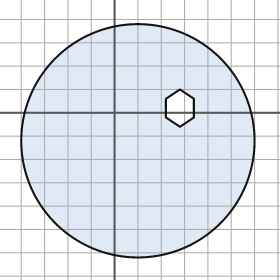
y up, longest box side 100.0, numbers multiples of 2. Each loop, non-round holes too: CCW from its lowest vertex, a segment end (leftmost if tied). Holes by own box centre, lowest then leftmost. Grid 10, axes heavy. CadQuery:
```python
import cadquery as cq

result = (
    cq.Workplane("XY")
    .moveTo(10.0, -12.0)
    .circle(50.0)
    .moveTo(28.0, -6.0)
    .lineTo(34.0, -2.0)
    .lineTo(34.0, 6.0)
    .lineTo(28.0, 10.0)
    .lineTo(22.0, 6.0)
    .lineTo(22.0, -2.0)
    .close()
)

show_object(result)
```